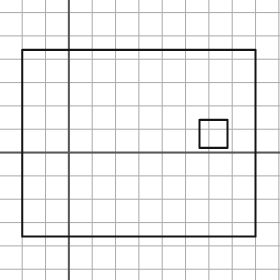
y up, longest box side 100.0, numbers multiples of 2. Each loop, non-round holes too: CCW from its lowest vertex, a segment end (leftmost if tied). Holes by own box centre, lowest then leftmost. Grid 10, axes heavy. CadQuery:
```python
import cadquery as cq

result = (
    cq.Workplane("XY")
    .moveTo(-20.0, -36.0)
    .lineTo(80.0, -36.0)
    .lineTo(80.0, 44.0)
    .lineTo(-20.0, 44.0)
    .close()
    .moveTo(56.0, 2.0)
    .lineTo(68.0, 2.0)
    .lineTo(68.0, 14.0)
    .lineTo(56.0, 14.0)
    .close()
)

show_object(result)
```